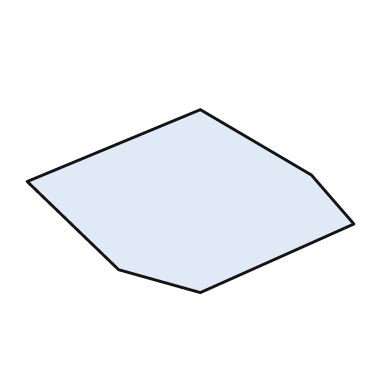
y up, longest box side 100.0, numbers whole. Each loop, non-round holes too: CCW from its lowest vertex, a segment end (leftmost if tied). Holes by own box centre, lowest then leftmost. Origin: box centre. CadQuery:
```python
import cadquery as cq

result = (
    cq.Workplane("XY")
    .moveTo(3.0, -28.0)
    .lineTo(50.0, -7.0)
    .lineTo(37.0, 8.0)
    .lineTo(3.0, 28.0)
    .lineTo(-50.0, 6.0)
    .lineTo(-22.0, -21.0)
    .close()
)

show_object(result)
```